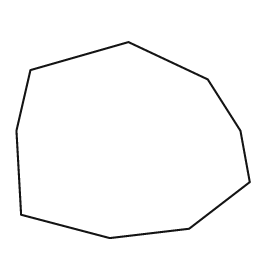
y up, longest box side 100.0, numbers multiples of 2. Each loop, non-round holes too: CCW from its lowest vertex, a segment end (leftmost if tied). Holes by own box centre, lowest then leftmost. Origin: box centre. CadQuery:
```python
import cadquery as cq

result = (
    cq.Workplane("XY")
    .moveTo(-10.0, -42.0)
    .lineTo(24.0, -38.0)
    .lineTo(50.0, -18.0)
    .lineTo(46.0, 4.0)
    .lineTo(32.0, 26.0)
    .lineTo(-2.0, 42.0)
    .lineTo(-44.0, 30.0)
    .lineTo(-50.0, 4.0)
    .lineTo(-48.0, -32.0)
    .close()
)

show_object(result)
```